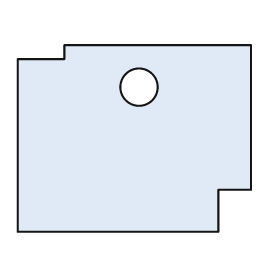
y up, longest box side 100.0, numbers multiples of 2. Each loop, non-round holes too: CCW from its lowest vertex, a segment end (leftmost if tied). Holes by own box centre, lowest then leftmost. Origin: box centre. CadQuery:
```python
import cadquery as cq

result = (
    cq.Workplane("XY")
    .moveTo(-50.0, -40.0)
    .lineTo(36.0, -40.0)
    .lineTo(36.0, -22.0)
    .lineTo(50.0, -22.0)
    .lineTo(50.0, 40.0)
    .lineTo(-30.0, 40.0)
    .lineTo(-30.0, 34.0)
    .lineTo(-50.0, 34.0)
    .close()
    .moveTo(2.0, 22.0)
    .circle(8.0)
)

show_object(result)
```